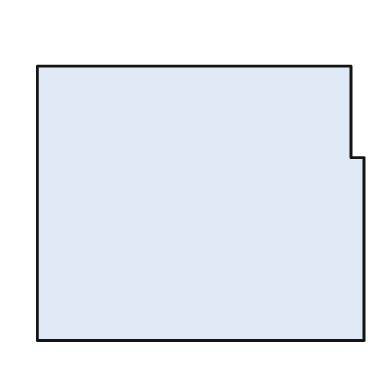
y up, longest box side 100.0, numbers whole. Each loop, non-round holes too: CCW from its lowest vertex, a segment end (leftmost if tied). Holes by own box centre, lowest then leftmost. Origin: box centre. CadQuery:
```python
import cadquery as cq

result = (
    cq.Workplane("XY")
    .moveTo(-50.0, -42.0)
    .lineTo(50.0, -42.0)
    .lineTo(50.0, 14.0)
    .lineTo(46.0, 14.0)
    .lineTo(46.0, 42.0)
    .lineTo(-50.0, 42.0)
    .close()
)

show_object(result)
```